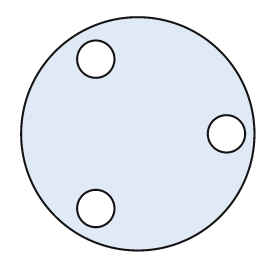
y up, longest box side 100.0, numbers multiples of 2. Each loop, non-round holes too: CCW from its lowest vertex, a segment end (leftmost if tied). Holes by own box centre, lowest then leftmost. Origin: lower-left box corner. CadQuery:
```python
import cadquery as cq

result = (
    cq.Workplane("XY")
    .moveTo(50.0, 50.0)
    .circle(50.0)
    .moveTo(32.0, 18.0)
    .circle(8.0)
    .moveTo(88.0, 50.0)
    .circle(8.0)
    .moveTo(32.0, 82.0)
    .circle(8.0)
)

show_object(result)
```